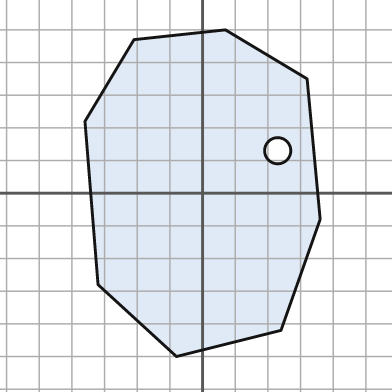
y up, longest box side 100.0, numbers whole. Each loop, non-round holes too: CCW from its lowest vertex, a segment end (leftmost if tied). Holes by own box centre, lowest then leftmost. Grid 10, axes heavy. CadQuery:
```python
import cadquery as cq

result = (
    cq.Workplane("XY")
    .moveTo(-8.0, -50.0)
    .lineTo(24.0, -42.0)
    .lineTo(36.0, -8.0)
    .lineTo(32.0, 35.0)
    .lineTo(7.0, 50.0)
    .lineTo(-21.0, 47.0)
    .lineTo(-36.0, 22.0)
    .lineTo(-32.0, -28.0)
    .close()
    .moveTo(23.0, 13.0)
    .circle(4.0)
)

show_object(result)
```